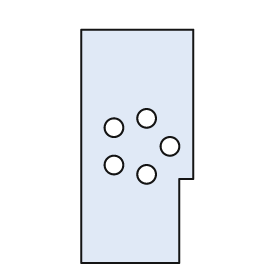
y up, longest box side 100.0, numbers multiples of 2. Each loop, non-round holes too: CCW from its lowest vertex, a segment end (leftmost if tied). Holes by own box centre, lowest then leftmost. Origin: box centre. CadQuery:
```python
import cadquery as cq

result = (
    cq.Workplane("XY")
    .moveTo(-24.0, -50.0)
    .lineTo(18.0, -50.0)
    .lineTo(18.0, -14.0)
    .lineTo(24.0, -14.0)
    .lineTo(24.0, 50.0)
    .lineTo(-24.0, 50.0)
    .close()
    .moveTo(4.0, -12.0)
    .circle(4.0)
    .moveTo(-10.0, -8.0)
    .circle(4.0)
    .moveTo(14.0, 0.0)
    .circle(4.0)
    .moveTo(-10.0, 8.0)
    .circle(4.0)
    .moveTo(4.0, 12.0)
    .circle(4.0)
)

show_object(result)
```